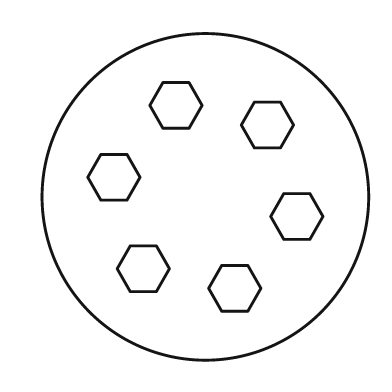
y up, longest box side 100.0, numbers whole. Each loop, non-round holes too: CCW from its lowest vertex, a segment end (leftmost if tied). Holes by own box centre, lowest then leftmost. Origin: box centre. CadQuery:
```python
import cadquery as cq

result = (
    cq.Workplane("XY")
    .moveTo(0.0, 0.0)
    .circle(50.0)
    .moveTo(5.0, -35.0)
    .lineTo(13.0, -35.0)
    .lineTo(17.0, -28.0)
    .lineTo(13.0, -21.0)
    .lineTo(5.0, -21.0)
    .lineTo(1.0, -28.0)
    .close()
    .moveTo(-23.0, -29.0)
    .lineTo(-15.0, -29.0)
    .lineTo(-11.0, -22.0)
    .lineTo(-15.0, -15.0)
    .lineTo(-23.0, -15.0)
    .lineTo(-27.0, -22.0)
    .close()
    .moveTo(24.0, -13.0)
    .lineTo(32.0, -13.0)
    .lineTo(36.0, -6.0)
    .lineTo(32.0, 1.0)
    .lineTo(24.0, 1.0)
    .lineTo(20.0, -6.0)
    .close()
    .moveTo(-32.0, -1.0)
    .lineTo(-24.0, -1.0)
    .lineTo(-20.0, 6.0)
    .lineTo(-24.0, 13.0)
    .lineTo(-32.0, 13.0)
    .lineTo(-36.0, 6.0)
    .close()
    .moveTo(15.0, 15.0)
    .lineTo(23.0, 15.0)
    .lineTo(27.0, 22.0)
    .lineTo(23.0, 29.0)
    .lineTo(15.0, 29.0)
    .lineTo(11.0, 22.0)
    .close()
    .moveTo(-13.0, 21.0)
    .lineTo(-5.0, 21.0)
    .lineTo(-1.0, 28.0)
    .lineTo(-5.0, 35.0)
    .lineTo(-13.0, 35.0)
    .lineTo(-17.0, 28.0)
    .close()
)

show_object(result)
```